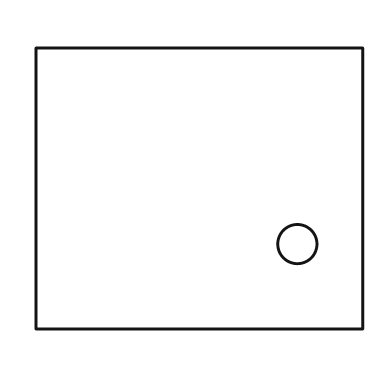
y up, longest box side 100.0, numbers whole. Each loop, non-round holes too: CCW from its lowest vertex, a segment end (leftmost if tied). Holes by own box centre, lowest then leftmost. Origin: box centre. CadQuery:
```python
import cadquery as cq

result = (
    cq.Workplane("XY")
    .moveTo(-50.0, -43.0)
    .lineTo(50.0, -43.0)
    .lineTo(50.0, 43.0)
    .lineTo(-50.0, 43.0)
    .close()
    .moveTo(30.0, -17.0)
    .circle(6.0)
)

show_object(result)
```